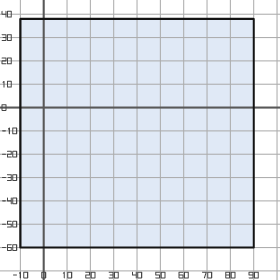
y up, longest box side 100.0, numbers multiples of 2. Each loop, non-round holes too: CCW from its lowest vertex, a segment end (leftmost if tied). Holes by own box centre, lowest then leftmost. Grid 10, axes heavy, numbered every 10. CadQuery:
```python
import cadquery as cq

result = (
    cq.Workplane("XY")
    .moveTo(-10.0, -60.0)
    .lineTo(90.0, -60.0)
    .lineTo(90.0, 38.0)
    .lineTo(-10.0, 38.0)
    .close()
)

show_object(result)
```